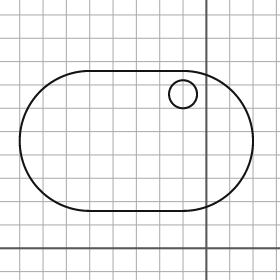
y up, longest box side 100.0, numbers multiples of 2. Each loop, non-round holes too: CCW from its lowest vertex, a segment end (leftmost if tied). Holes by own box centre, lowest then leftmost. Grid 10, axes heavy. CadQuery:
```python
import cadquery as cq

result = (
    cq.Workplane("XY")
    .moveTo(-50.0, 16.0)
    .lineTo(-10.0, 16.0)
    .threePointArc((20.0, 46.0), (-10.0, 76.0))
    .lineTo(-50.0, 76.0)
    .threePointArc((-80.0, 46.0), (-50.0, 16.0))
    .close()
    .moveTo(-10.0, 66.0)
    .circle(6.0)
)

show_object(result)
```